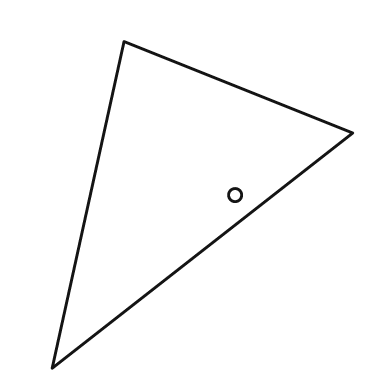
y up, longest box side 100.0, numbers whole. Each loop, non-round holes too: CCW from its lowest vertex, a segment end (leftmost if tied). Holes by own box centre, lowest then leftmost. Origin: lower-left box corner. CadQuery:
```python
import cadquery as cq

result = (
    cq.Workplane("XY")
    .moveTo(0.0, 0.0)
    .lineTo(92.0, 72.0)
    .lineTo(22.0, 100.0)
    .close()
    .moveTo(56.0, 53.0)
    .circle(2.0)
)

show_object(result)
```